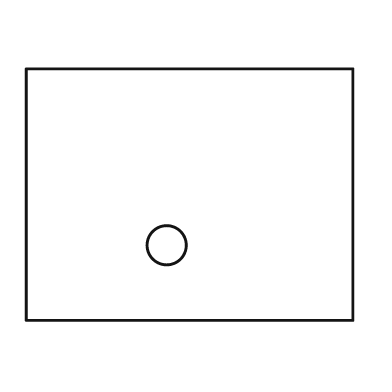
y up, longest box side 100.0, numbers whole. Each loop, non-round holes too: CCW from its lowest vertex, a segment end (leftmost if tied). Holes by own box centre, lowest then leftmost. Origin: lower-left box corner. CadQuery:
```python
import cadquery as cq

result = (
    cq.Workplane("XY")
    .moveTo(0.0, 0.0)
    .lineTo(100.0, 0.0)
    .lineTo(100.0, 77.0)
    .lineTo(0.0, 77.0)
    .close()
    .moveTo(43.0, 23.0)
    .circle(6.0)
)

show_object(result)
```